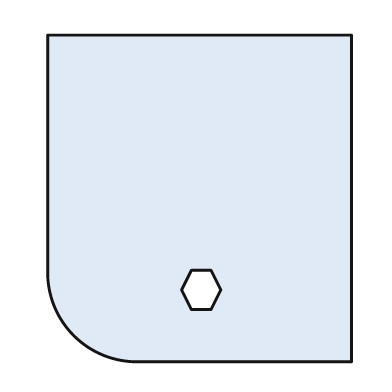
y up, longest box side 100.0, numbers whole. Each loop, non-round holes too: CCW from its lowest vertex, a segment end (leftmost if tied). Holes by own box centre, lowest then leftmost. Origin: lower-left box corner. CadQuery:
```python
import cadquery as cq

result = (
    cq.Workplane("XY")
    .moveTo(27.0, 0.0)
    .lineTo(93.0, 0.0)
    .lineTo(93.0, 100.0)
    .lineTo(0.0, 100.0)
    .lineTo(0.0, 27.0)
    .threePointArc((8.0, 8.0), (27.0, 0.0))
    .close()
    .moveTo(44.0, 16.0)
    .lineTo(50.0, 16.0)
    .lineTo(53.0, 22.0)
    .lineTo(50.0, 28.0)
    .lineTo(44.0, 28.0)
    .lineTo(41.0, 22.0)
    .close()
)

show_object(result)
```